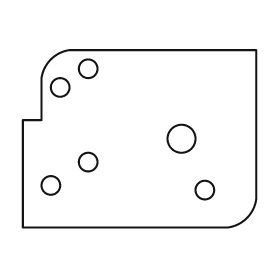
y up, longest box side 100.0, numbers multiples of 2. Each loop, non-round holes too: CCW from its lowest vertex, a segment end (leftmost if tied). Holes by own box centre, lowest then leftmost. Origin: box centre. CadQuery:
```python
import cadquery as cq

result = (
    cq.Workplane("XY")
    .moveTo(-50.0, -38.0)
    .lineTo(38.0, -38.0)
    .threePointArc((46.0, -34.0), (50.0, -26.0))
    .lineTo(50.0, 38.0)
    .lineTo(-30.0, 38.0)
    .threePointArc((-38.0, 34.0), (-42.0, 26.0))
    .lineTo(-42.0, 8.0)
    .lineTo(-50.0, 8.0)
    .close()
    .moveTo(28.0, -22.0)
    .circle(4.0)
    .moveTo(-38.0, -20.0)
    .circle(4.0)
    .moveTo(-22.0, -10.0)
    .circle(4.0)
    .moveTo(18.0, 0.0)
    .circle(6.0)
    .moveTo(-34.0, 22.0)
    .circle(4.0)
    .moveTo(-22.0, 30.0)
    .circle(4.0)
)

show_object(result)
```